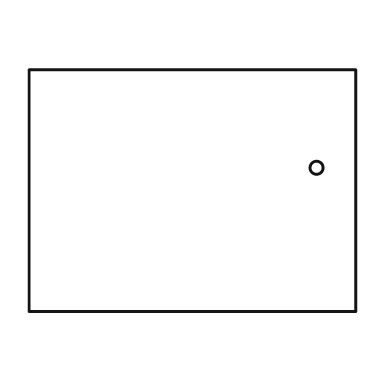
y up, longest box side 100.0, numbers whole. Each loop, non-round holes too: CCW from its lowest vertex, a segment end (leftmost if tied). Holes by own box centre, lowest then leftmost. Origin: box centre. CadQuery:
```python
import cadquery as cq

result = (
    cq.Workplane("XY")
    .moveTo(-50.0, -37.0)
    .lineTo(50.0, -37.0)
    .lineTo(50.0, 37.0)
    .lineTo(-50.0, 37.0)
    .close()
    .moveTo(38.0, 7.0)
    .circle(2.0)
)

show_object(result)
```